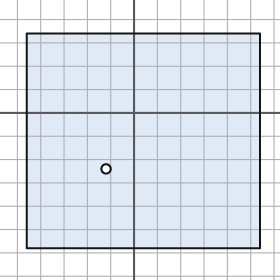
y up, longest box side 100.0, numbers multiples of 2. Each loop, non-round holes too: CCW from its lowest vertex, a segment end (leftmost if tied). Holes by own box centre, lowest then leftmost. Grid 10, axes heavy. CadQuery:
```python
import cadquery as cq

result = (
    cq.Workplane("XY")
    .moveTo(-46.0, -58.0)
    .lineTo(54.0, -58.0)
    .lineTo(54.0, 34.0)
    .lineTo(-46.0, 34.0)
    .close()
    .moveTo(-12.0, -24.0)
    .circle(2.0)
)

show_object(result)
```